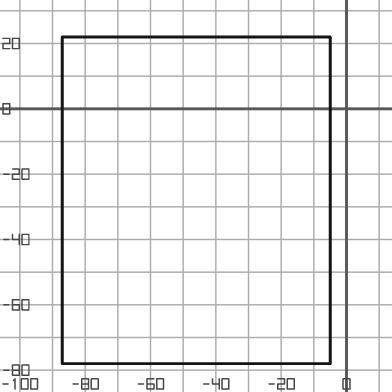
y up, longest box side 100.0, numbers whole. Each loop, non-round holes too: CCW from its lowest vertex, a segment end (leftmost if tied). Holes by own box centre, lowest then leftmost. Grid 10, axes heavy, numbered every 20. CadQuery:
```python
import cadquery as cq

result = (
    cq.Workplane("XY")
    .moveTo(-87.0, -78.0)
    .lineTo(-5.0, -78.0)
    .lineTo(-5.0, 22.0)
    .lineTo(-87.0, 22.0)
    .close()
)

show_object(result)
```